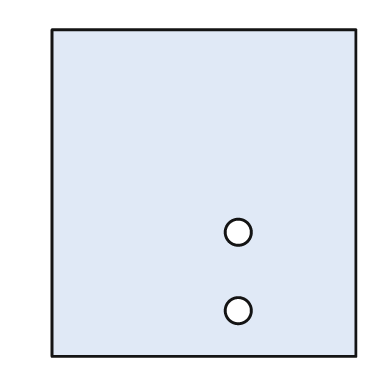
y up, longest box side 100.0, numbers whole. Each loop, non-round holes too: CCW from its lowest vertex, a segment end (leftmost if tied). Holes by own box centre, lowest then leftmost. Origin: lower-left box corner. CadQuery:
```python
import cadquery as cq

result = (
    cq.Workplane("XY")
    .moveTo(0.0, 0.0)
    .lineTo(93.0, 0.0)
    .lineTo(93.0, 100.0)
    .lineTo(0.0, 100.0)
    .close()
    .moveTo(57.0, 14.0)
    .circle(4.0)
    .moveTo(57.0, 38.0)
    .circle(4.0)
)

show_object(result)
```